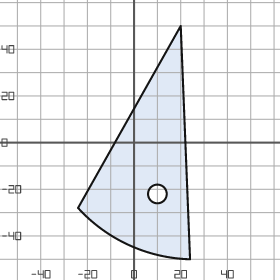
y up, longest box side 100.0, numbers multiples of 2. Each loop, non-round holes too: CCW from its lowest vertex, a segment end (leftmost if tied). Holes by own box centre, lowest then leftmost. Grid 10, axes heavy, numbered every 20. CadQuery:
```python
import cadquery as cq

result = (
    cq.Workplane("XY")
    .moveTo(24.0, -50.0)
    .lineTo(20.0, 50.0)
    .lineTo(-24.0, -28.0)
    .threePointArc((-2.0, -44.0), (24.0, -50.0))
    .close()
    .moveTo(10.0, -22.0)
    .circle(4.0)
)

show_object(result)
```